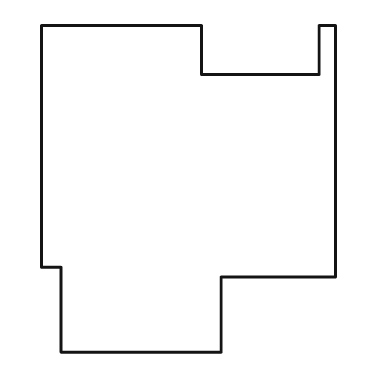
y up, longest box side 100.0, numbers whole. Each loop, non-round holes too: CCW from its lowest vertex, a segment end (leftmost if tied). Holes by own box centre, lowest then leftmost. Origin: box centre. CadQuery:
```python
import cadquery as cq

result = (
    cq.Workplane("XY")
    .moveTo(-39.0, -50.0)
    .lineTo(10.0, -50.0)
    .lineTo(10.0, -27.0)
    .lineTo(45.0, -27.0)
    .lineTo(45.0, 50.0)
    .lineTo(40.0, 50.0)
    .lineTo(40.0, 35.0)
    .lineTo(4.0, 35.0)
    .lineTo(4.0, 50.0)
    .lineTo(-45.0, 50.0)
    .lineTo(-45.0, -24.0)
    .lineTo(-39.0, -24.0)
    .close()
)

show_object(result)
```